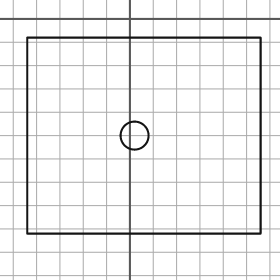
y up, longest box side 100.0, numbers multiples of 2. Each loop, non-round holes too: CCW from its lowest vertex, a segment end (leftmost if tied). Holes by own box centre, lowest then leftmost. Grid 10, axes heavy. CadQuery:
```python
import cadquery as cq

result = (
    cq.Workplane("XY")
    .moveTo(-44.0, -92.0)
    .lineTo(56.0, -92.0)
    .lineTo(56.0, -8.0)
    .lineTo(-44.0, -8.0)
    .close()
    .moveTo(2.0, -50.0)
    .circle(6.0)
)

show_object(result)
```